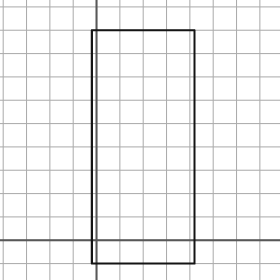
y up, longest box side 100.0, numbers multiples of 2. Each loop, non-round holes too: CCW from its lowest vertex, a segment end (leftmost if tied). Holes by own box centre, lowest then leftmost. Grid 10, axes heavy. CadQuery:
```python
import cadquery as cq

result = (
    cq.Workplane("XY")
    .moveTo(-2.0, -10.0)
    .lineTo(42.0, -10.0)
    .lineTo(42.0, 90.0)
    .lineTo(-2.0, 90.0)
    .close()
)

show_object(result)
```